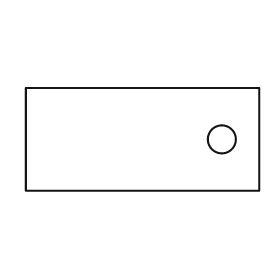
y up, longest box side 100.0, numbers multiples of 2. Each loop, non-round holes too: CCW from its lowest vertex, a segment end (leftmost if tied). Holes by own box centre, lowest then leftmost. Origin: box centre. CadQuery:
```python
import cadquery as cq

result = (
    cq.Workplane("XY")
    .moveTo(-50.0, -22.0)
    .lineTo(50.0, -22.0)
    .lineTo(50.0, 22.0)
    .lineTo(-50.0, 22.0)
    .close()
    .moveTo(34.0, 0.0)
    .circle(6.0)
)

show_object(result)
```